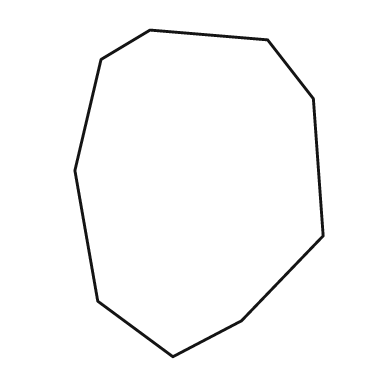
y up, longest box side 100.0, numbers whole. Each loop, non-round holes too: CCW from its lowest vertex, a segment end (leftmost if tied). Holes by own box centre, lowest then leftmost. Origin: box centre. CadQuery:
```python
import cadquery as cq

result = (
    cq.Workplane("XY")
    .moveTo(-8.0, -50.0)
    .lineTo(13.0, -39.0)
    .lineTo(38.0, -13.0)
    .lineTo(35.0, 29.0)
    .lineTo(21.0, 47.0)
    .lineTo(-15.0, 50.0)
    .lineTo(-30.0, 41.0)
    .lineTo(-38.0, 7.0)
    .lineTo(-31.0, -33.0)
    .close()
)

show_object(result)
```